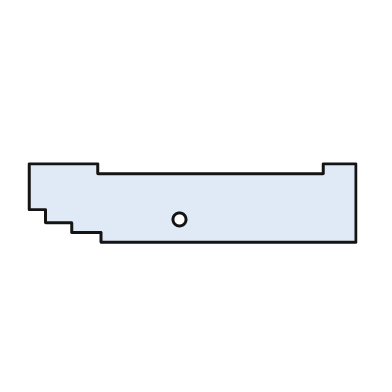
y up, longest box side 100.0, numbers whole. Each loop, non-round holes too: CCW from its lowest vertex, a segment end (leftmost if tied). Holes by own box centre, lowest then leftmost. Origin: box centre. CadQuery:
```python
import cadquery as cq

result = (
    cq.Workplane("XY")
    .moveTo(-28.0, -12.0)
    .lineTo(50.0, -12.0)
    .lineTo(50.0, 12.0)
    .lineTo(40.0, 12.0)
    .lineTo(40.0, 9.0)
    .lineTo(-29.0, 9.0)
    .lineTo(-29.0, 12.0)
    .lineTo(-50.0, 12.0)
    .lineTo(-50.0, -2.0)
    .lineTo(-45.0, -2.0)
    .lineTo(-45.0, -6.0)
    .lineTo(-37.0, -6.0)
    .lineTo(-37.0, -9.0)
    .lineTo(-28.0, -9.0)
    .close()
    .moveTo(-4.0, -5.0)
    .circle(2.0)
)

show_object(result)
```